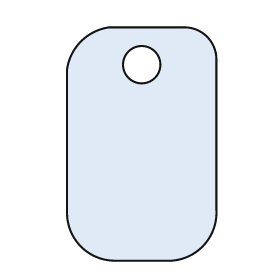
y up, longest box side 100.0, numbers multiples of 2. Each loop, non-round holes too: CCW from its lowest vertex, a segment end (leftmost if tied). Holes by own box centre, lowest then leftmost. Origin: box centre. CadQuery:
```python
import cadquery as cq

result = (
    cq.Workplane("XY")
    .moveTo(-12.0, -50.0)
    .lineTo(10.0, -50.0)
    .threePointArc((26.0, -44.0), (32.0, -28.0))
    .lineTo(32.0, 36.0)
    .threePointArc((28.0, 46.0), (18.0, 50.0))
    .lineTo(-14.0, 50.0)
    .threePointArc((-26.0, 44.0), (-32.0, 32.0))
    .lineTo(-32.0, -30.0)
    .threePointArc((-26.0, -44.0), (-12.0, -50.0))
    .close()
    .moveTo(0.0, 34.0)
    .circle(8.0)
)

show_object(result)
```